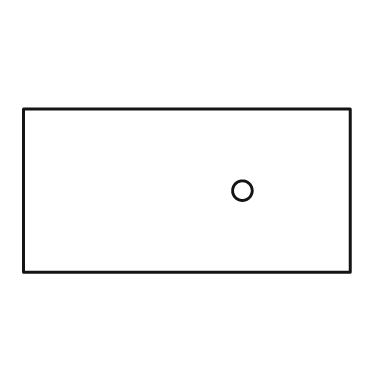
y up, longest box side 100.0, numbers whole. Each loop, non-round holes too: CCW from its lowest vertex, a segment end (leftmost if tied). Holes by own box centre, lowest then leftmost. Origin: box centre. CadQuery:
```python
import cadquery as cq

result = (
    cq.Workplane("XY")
    .moveTo(-50.0, -25.0)
    .lineTo(50.0, -25.0)
    .lineTo(50.0, 25.0)
    .lineTo(-50.0, 25.0)
    .close()
    .moveTo(17.0, 0.0)
    .circle(3.0)
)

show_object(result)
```